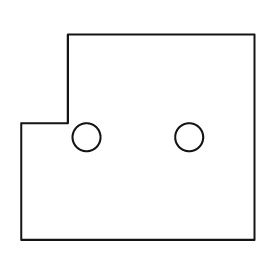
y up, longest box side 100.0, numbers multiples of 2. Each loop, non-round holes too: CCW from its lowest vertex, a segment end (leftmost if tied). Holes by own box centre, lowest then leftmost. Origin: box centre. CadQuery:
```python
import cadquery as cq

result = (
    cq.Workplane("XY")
    .moveTo(-50.0, -44.0)
    .lineTo(50.0, -44.0)
    .lineTo(50.0, 44.0)
    .lineTo(-30.0, 44.0)
    .lineTo(-30.0, 6.0)
    .lineTo(-50.0, 6.0)
    .close()
    .moveTo(-22.0, 0.0)
    .circle(6.0)
    .moveTo(22.0, 0.0)
    .circle(6.0)
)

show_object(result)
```